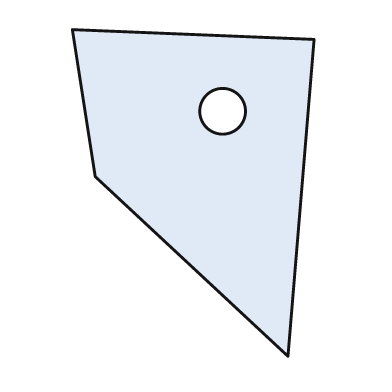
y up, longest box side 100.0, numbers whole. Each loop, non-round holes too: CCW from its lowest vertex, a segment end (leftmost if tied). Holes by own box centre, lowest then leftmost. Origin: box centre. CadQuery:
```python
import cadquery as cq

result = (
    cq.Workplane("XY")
    .moveTo(29.0, -50.0)
    .lineTo(37.0, 47.0)
    .lineTo(-37.0, 50.0)
    .lineTo(-30.0, 5.0)
    .close()
    .moveTo(9.0, 25.0)
    .circle(7.0)
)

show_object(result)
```